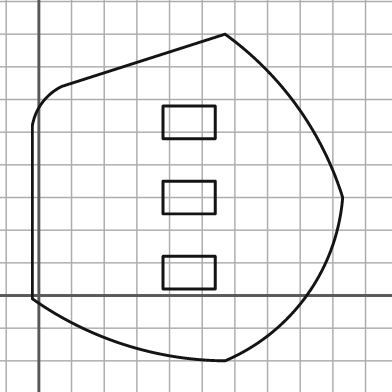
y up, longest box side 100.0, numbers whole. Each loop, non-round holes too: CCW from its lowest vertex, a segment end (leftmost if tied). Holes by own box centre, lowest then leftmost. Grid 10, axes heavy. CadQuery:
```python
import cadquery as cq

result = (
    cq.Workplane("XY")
    .moveTo(57.0, -20.0)
    .threePointArc((82.0, 0.0), (93.0, 30.0))
    .threePointArc((79.0, 58.0), (57.0, 80.0))
    .lineTo(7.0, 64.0)
    .threePointArc((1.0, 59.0), (-2.0, 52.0))
    .lineTo(-2.0, -1.0)
    .threePointArc((26.0, -15.0), (57.0, -20.0))
    .close()
    .moveTo(38.0, 2.0)
    .lineTo(54.0, 2.0)
    .lineTo(54.0, 12.0)
    .lineTo(38.0, 12.0)
    .close()
    .moveTo(38.0, 25.0)
    .lineTo(54.0, 25.0)
    .lineTo(54.0, 35.0)
    .lineTo(38.0, 35.0)
    .close()
    .moveTo(38.0, 48.0)
    .lineTo(54.0, 48.0)
    .lineTo(54.0, 58.0)
    .lineTo(38.0, 58.0)
    .close()
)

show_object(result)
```